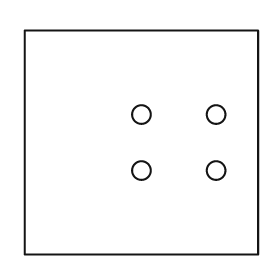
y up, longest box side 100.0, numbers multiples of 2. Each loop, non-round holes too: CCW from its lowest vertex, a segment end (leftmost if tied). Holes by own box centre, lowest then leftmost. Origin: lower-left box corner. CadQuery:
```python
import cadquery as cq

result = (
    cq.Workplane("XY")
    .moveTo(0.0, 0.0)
    .lineTo(100.0, 0.0)
    .lineTo(100.0, 96.0)
    .lineTo(0.0, 96.0)
    .close()
    .moveTo(50.0, 36.0)
    .circle(4.0)
    .moveTo(82.0, 36.0)
    .circle(4.0)
    .moveTo(50.0, 60.0)
    .circle(4.0)
    .moveTo(82.0, 60.0)
    .circle(4.0)
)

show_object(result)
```